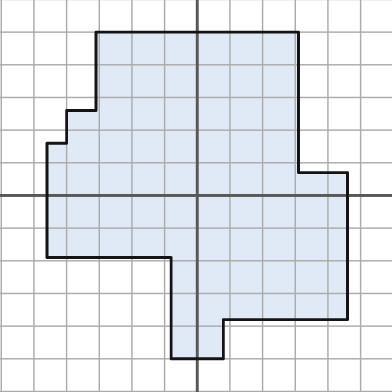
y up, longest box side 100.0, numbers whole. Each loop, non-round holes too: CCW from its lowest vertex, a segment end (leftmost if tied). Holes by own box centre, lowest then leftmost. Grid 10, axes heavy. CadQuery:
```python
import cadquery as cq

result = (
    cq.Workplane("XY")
    .moveTo(-8.0, -50.0)
    .lineTo(8.0, -50.0)
    .lineTo(8.0, -38.0)
    .lineTo(46.0, -38.0)
    .lineTo(46.0, 7.0)
    .lineTo(31.0, 7.0)
    .lineTo(31.0, 50.0)
    .lineTo(-31.0, 50.0)
    .lineTo(-31.0, 26.0)
    .lineTo(-40.0, 26.0)
    .lineTo(-40.0, 16.0)
    .lineTo(-46.0, 16.0)
    .lineTo(-46.0, -19.0)
    .lineTo(-8.0, -19.0)
    .close()
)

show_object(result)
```